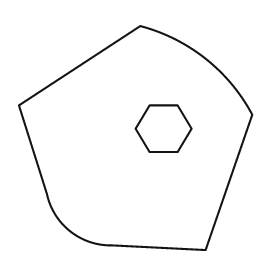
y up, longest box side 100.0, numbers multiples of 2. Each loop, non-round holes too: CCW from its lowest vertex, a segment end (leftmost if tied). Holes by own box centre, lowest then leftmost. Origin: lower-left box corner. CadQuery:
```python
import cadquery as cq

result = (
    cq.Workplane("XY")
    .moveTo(80.0, 0.0)
    .lineTo(100.0, 58.0)
    .threePointArc((80.0, 82.0), (52.0, 96.0))
    .lineTo(0.0, 62.0)
    .lineTo(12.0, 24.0)
    .threePointArc((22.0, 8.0), (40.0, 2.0))
    .close()
    .moveTo(56.0, 42.0)
    .lineTo(68.0, 42.0)
    .lineTo(74.0, 52.0)
    .lineTo(68.0, 62.0)
    .lineTo(56.0, 62.0)
    .lineTo(50.0, 52.0)
    .close()
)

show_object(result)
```